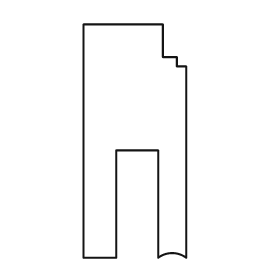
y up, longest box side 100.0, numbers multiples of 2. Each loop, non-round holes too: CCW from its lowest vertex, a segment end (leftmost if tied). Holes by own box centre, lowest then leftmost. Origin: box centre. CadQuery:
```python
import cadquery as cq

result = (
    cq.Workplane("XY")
    .moveTo(-22.0, -50.0)
    .lineTo(-8.0, -50.0)
    .lineTo(-8.0, -4.0)
    .lineTo(10.0, -4.0)
    .lineTo(10.0, -50.0)
    .threePointArc((16.0, -48.0), (22.0, -50.0))
    .lineTo(22.0, 32.0)
    .lineTo(18.0, 32.0)
    .lineTo(18.0, 36.0)
    .lineTo(12.0, 36.0)
    .lineTo(12.0, 50.0)
    .lineTo(-22.0, 50.0)
    .close()
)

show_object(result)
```